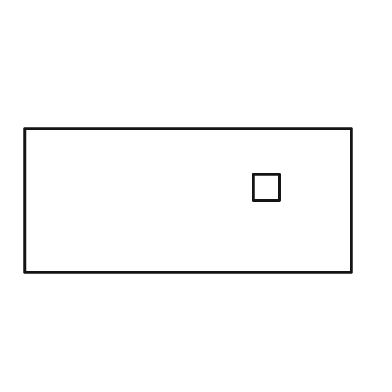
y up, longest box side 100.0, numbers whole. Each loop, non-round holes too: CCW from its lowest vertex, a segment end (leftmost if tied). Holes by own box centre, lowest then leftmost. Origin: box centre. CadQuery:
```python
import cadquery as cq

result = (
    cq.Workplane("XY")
    .moveTo(-50.0, -22.0)
    .lineTo(50.0, -22.0)
    .lineTo(50.0, 22.0)
    .lineTo(-50.0, 22.0)
    .close()
    .moveTo(20.0, 0.0)
    .lineTo(28.0, 0.0)
    .lineTo(28.0, 8.0)
    .lineTo(20.0, 8.0)
    .close()
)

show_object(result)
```